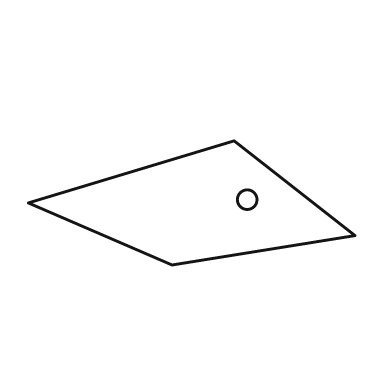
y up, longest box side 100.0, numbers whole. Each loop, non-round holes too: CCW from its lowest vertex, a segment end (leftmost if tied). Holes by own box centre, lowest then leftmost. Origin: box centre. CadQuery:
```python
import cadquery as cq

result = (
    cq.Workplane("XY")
    .moveTo(-6.0, -19.0)
    .lineTo(50.0, -10.0)
    .lineTo(13.0, 19.0)
    .lineTo(-50.0, 0.0)
    .close()
    .moveTo(17.0, 1.0)
    .circle(3.0)
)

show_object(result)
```